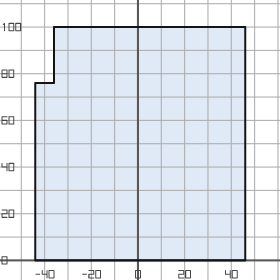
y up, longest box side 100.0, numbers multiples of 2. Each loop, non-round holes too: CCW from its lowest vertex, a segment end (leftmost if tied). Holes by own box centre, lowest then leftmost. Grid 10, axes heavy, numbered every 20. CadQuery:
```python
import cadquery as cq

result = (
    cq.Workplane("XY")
    .moveTo(-44.0, 0.0)
    .lineTo(46.0, 0.0)
    .lineTo(46.0, 100.0)
    .lineTo(-36.0, 100.0)
    .lineTo(-36.0, 76.0)
    .lineTo(-44.0, 76.0)
    .close()
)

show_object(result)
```